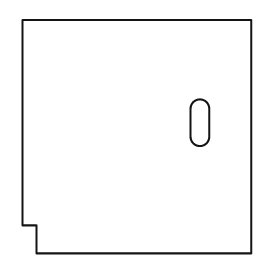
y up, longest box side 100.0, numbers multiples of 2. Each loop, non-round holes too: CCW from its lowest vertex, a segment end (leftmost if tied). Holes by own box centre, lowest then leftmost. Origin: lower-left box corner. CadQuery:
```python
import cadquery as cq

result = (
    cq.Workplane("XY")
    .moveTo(6.0, 0.0)
    .lineTo(98.0, 0.0)
    .lineTo(98.0, 100.0)
    .lineTo(0.0, 100.0)
    .lineTo(0.0, 12.0)
    .lineTo(6.0, 12.0)
    .close()
    .moveTo(72.0, 50.0)
    .threePointArc((76.0, 46.0), (80.0, 50.0))
    .lineTo(80.0, 62.0)
    .threePointArc((76.0, 66.0), (72.0, 62.0))
    .close()
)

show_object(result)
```